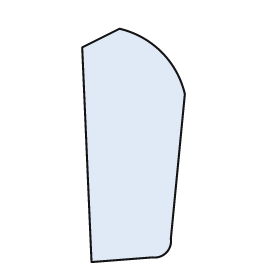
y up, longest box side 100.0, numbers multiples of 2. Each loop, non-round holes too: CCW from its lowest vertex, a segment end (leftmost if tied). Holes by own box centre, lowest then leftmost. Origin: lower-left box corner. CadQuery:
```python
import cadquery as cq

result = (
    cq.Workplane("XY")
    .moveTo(4.0, 0.0)
    .lineTo(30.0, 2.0)
    .threePointArc((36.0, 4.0), (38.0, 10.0))
    .lineTo(44.0, 72.0)
    .threePointArc((34.0, 90.0), (16.0, 100.0))
    .lineTo(0.0, 92.0)
    .close()
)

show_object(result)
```